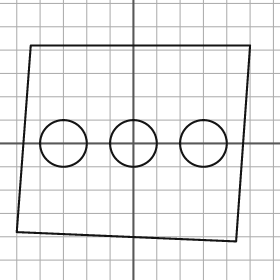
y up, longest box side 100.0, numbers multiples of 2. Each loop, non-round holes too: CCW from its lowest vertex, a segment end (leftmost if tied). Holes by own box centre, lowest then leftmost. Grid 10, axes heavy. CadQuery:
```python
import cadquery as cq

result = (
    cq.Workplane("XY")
    .moveTo(44.0, -42.0)
    .lineTo(50.0, 42.0)
    .lineTo(-44.0, 42.0)
    .lineTo(-50.0, -38.0)
    .close()
    .moveTo(-30.0, 0.0)
    .circle(10.0)
    .moveTo(0.0, 0.0)
    .circle(10.0)
    .moveTo(30.0, 0.0)
    .circle(10.0)
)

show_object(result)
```